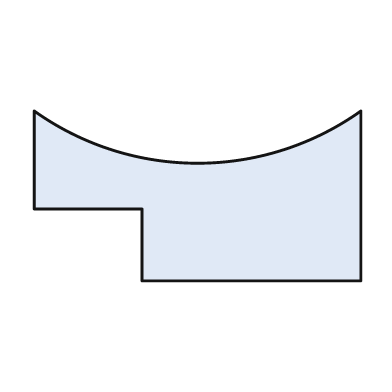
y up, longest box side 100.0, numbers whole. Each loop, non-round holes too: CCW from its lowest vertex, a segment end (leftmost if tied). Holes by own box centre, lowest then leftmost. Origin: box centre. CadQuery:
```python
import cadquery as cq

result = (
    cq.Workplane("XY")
    .moveTo(-17.0, -26.0)
    .lineTo(50.0, -26.0)
    .lineTo(50.0, 26.0)
    .threePointArc((0.0, 10.0), (-50.0, 26.0))
    .lineTo(-50.0, -4.0)
    .lineTo(-17.0, -4.0)
    .close()
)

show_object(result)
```